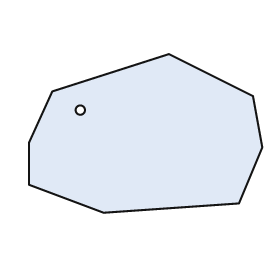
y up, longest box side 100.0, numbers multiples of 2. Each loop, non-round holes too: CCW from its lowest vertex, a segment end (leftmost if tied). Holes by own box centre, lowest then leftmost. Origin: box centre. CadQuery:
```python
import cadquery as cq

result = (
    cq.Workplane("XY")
    .moveTo(-18.0, -34.0)
    .lineTo(40.0, -30.0)
    .lineTo(50.0, -6.0)
    .lineTo(46.0, 16.0)
    .lineTo(10.0, 34.0)
    .lineTo(-40.0, 18.0)
    .lineTo(-50.0, -4.0)
    .lineTo(-50.0, -22.0)
    .close()
    .moveTo(-28.0, 10.0)
    .circle(2.0)
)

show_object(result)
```